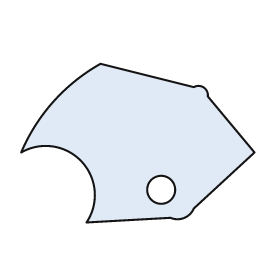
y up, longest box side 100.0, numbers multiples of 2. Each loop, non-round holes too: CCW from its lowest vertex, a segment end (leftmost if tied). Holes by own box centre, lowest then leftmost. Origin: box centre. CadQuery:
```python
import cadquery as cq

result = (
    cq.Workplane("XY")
    .moveTo(-22.0, -34.0)
    .lineTo(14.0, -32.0)
    .threePointArc((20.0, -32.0), (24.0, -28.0))
    .lineTo(50.0, -4.0)
    .lineTo(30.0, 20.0)
    .threePointArc((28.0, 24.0), (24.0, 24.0))
    .lineTo(-16.0, 34.0)
    .threePointArc((-36.0, 18.0), (-50.0, -4.0))
    .threePointArc((-24.0, -8.0), (-22.0, -34.0))
    .close()
    .moveTo(10.0, -20.0)
    .circle(6.0)
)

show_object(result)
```